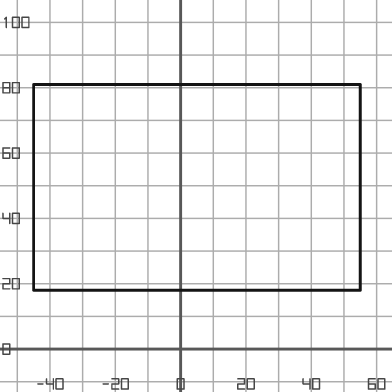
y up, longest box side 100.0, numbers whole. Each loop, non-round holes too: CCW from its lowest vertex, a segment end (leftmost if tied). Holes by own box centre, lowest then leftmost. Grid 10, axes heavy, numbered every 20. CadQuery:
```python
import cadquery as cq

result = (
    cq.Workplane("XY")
    .moveTo(-45.0, 18.0)
    .lineTo(55.0, 18.0)
    .lineTo(55.0, 81.0)
    .lineTo(-45.0, 81.0)
    .close()
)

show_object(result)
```